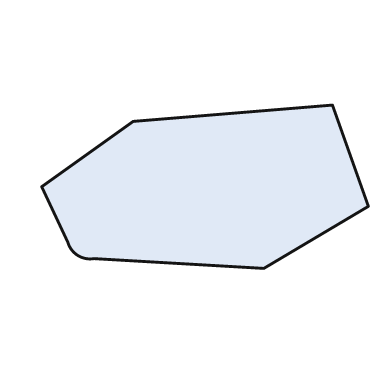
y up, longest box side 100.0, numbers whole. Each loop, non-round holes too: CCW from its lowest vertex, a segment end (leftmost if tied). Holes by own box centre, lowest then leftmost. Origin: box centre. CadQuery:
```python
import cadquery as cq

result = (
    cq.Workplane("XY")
    .moveTo(18.0, -25.0)
    .lineTo(50.0, -6.0)
    .lineTo(39.0, 25.0)
    .lineTo(-22.0, 20.0)
    .lineTo(-50.0, 0.0)
    .lineTo(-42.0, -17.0)
    .threePointArc((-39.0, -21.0), (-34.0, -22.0))
    .close()
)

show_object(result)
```